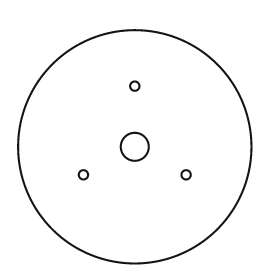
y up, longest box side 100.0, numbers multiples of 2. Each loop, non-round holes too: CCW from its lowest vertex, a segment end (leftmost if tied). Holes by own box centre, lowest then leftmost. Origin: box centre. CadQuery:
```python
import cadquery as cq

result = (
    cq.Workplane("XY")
    .moveTo(0.0, 0.0)
    .circle(50.0)
    .moveTo(-22.0, -12.0)
    .circle(2.0)
    .moveTo(22.0, -12.0)
    .circle(2.0)
    .moveTo(0.0, 0.0)
    .circle(6.0)
    .moveTo(0.0, 26.0)
    .circle(2.0)
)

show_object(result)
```